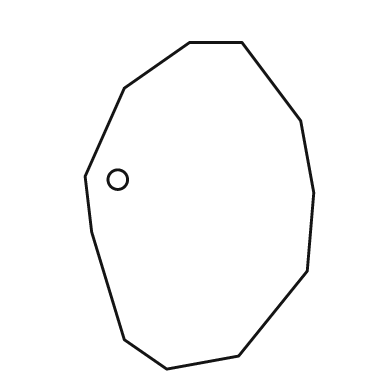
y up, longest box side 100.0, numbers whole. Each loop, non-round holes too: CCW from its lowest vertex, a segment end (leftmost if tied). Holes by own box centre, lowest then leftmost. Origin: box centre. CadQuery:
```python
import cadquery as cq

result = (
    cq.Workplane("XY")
    .moveTo(-10.0, -50.0)
    .lineTo(12.0, -46.0)
    .lineTo(33.0, -20.0)
    .lineTo(35.0, 4.0)
    .lineTo(31.0, 26.0)
    .lineTo(13.0, 50.0)
    .lineTo(-3.0, 50.0)
    .lineTo(-23.0, 36.0)
    .lineTo(-35.0, 9.0)
    .lineTo(-33.0, -8.0)
    .lineTo(-23.0, -41.0)
    .close()
    .moveTo(-25.0, 8.0)
    .circle(3.0)
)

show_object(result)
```